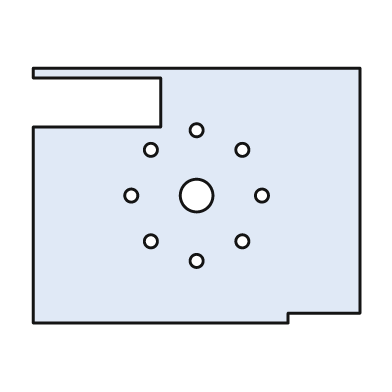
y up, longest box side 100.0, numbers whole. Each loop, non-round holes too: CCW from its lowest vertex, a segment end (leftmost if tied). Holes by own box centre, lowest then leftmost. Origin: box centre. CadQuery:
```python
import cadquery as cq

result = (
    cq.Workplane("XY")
    .moveTo(-50.0, -39.0)
    .lineTo(28.0, -39.0)
    .lineTo(28.0, -36.0)
    .lineTo(50.0, -36.0)
    .lineTo(50.0, 39.0)
    .lineTo(-50.0, 39.0)
    .lineTo(-50.0, 36.0)
    .lineTo(-11.0, 36.0)
    .lineTo(-11.0, 21.0)
    .lineTo(-50.0, 21.0)
    .close()
    .moveTo(0.0, -20.0)
    .circle(2.0)
    .moveTo(-14.0, -14.0)
    .circle(2.0)
    .moveTo(14.0, -14.0)
    .circle(2.0)
    .moveTo(-20.0, 0.0)
    .circle(2.0)
    .moveTo(0.0, 0.0)
    .circle(5.0)
    .moveTo(20.0, 0.0)
    .circle(2.0)
    .moveTo(-14.0, 14.0)
    .circle(2.0)
    .moveTo(14.0, 14.0)
    .circle(2.0)
    .moveTo(0.0, 20.0)
    .circle(2.0)
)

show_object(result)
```